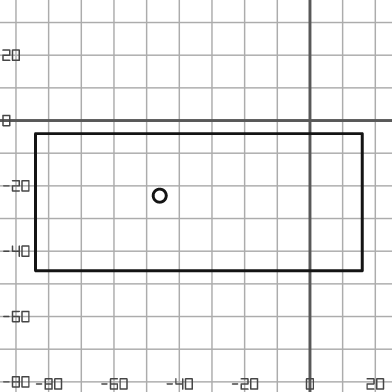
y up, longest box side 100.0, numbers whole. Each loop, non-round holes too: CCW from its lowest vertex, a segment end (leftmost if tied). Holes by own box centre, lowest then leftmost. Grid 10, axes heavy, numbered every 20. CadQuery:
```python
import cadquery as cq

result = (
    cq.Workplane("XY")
    .moveTo(-84.0, -46.0)
    .lineTo(16.0, -46.0)
    .lineTo(16.0, -4.0)
    .lineTo(-84.0, -4.0)
    .close()
    .moveTo(-46.0, -23.0)
    .circle(2.0)
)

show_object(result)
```